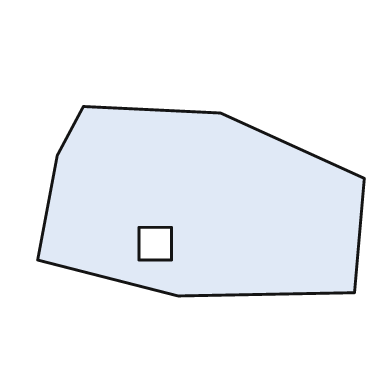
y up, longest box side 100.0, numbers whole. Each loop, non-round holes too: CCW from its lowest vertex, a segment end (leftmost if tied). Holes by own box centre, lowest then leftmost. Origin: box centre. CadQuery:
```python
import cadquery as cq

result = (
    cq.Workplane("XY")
    .moveTo(-7.0, -29.0)
    .lineTo(47.0, -28.0)
    .lineTo(50.0, 7.0)
    .lineTo(6.0, 27.0)
    .lineTo(-36.0, 29.0)
    .lineTo(-44.0, 14.0)
    .lineTo(-50.0, -18.0)
    .close()
    .moveTo(-19.0, -18.0)
    .lineTo(-9.0, -18.0)
    .lineTo(-9.0, -8.0)
    .lineTo(-19.0, -8.0)
    .close()
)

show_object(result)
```